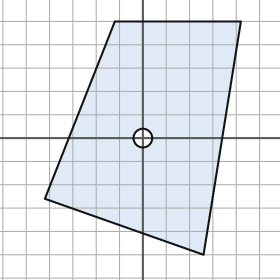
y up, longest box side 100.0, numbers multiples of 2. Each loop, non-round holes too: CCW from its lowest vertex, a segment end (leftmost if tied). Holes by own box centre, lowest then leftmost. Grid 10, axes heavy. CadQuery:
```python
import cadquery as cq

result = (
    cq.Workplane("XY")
    .moveTo(26.0, -50.0)
    .lineTo(42.0, 50.0)
    .lineTo(-12.0, 50.0)
    .lineTo(-42.0, -26.0)
    .close()
    .moveTo(0.0, 0.0)
    .circle(4.0)
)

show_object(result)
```